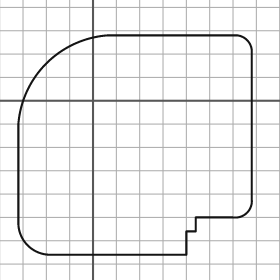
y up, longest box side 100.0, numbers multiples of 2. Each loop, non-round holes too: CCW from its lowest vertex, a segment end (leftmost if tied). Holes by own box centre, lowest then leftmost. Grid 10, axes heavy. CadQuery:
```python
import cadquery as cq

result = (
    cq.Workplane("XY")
    .moveTo(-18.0, -66.0)
    .lineTo(40.0, -66.0)
    .lineTo(40.0, -56.0)
    .lineTo(44.0, -56.0)
    .lineTo(44.0, -50.0)
    .lineTo(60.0, -50.0)
    .threePointArc((66.0, -48.0), (68.0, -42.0))
    .lineTo(68.0, 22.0)
    .threePointArc((66.0, 26.0), (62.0, 28.0))
    .lineTo(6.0, 28.0)
    .threePointArc((-20.0, 16.0), (-32.0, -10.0))
    .lineTo(-32.0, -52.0)
    .threePointArc((-28.0, -62.0), (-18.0, -66.0))
    .close()
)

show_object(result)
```